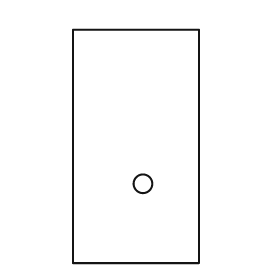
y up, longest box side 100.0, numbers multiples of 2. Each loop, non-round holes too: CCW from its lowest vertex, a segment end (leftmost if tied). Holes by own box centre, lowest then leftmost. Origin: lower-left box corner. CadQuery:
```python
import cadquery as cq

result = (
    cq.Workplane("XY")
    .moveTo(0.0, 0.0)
    .lineTo(54.0, 0.0)
    .lineTo(54.0, 100.0)
    .lineTo(0.0, 100.0)
    .close()
    .moveTo(30.0, 34.0)
    .circle(4.0)
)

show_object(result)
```